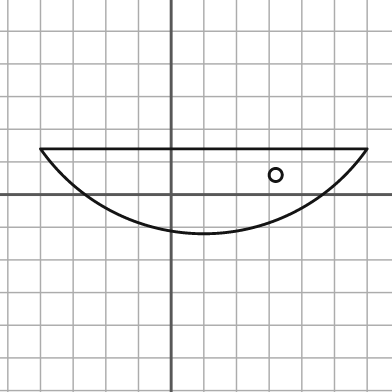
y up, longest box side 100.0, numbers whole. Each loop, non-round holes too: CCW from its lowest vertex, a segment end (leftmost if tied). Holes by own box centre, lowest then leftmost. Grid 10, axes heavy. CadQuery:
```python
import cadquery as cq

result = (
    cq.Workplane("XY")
    .moveTo(-40.0, 14.0)
    .threePointArc((10.0, -12.0), (60.0, 14.0))
    .close()
    .moveTo(32.0, 6.0)
    .circle(2.0)
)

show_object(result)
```